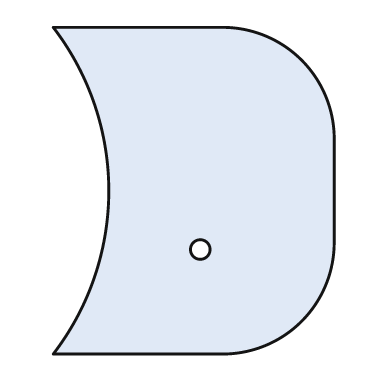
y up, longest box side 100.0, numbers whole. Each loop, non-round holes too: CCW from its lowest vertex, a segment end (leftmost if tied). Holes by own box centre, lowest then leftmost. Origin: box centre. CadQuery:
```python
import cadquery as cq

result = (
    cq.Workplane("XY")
    .moveTo(-43.0, -50.0)
    .lineTo(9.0, -50.0)
    .threePointArc((33.0, -40.0), (43.0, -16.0))
    .lineTo(43.0, 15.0)
    .threePointArc((33.0, 40.0), (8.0, 50.0))
    .lineTo(-43.0, 50.0)
    .threePointArc((-26.0, 0.0), (-43.0, -50.0))
    .close()
    .moveTo(2.0, -18.0)
    .circle(3.0)
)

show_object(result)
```